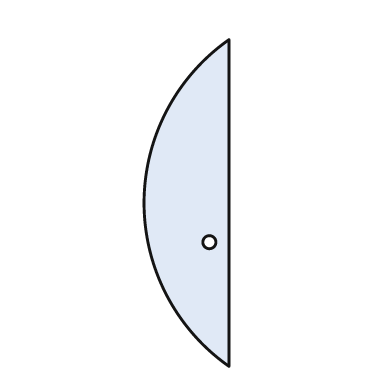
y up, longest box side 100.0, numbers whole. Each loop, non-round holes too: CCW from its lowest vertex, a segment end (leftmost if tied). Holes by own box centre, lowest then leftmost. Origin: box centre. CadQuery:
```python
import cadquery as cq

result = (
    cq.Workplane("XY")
    .moveTo(13.0, -50.0)
    .lineTo(13.0, 50.0)
    .threePointArc((-13.0, 0.0), (13.0, -50.0))
    .close()
    .moveTo(7.0, -12.0)
    .circle(2.0)
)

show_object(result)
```